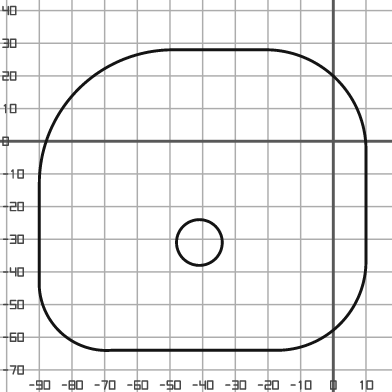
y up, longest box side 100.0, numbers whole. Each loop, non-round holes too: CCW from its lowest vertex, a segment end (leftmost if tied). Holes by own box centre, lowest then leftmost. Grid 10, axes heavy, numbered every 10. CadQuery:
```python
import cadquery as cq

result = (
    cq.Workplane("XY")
    .moveTo(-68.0, -64.0)
    .lineTo(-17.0, -64.0)
    .threePointArc((2.0, -56.0), (10.0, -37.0))
    .lineTo(10.0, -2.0)
    .threePointArc((1.0, 19.0), (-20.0, 28.0))
    .lineTo(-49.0, 28.0)
    .threePointArc((-78.0, 16.0), (-90.0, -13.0))
    .lineTo(-90.0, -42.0)
    .threePointArc((-84.0, -58.0), (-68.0, -64.0))
    .close()
    .moveTo(-41.0, -31.0)
    .circle(7.0)
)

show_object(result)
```